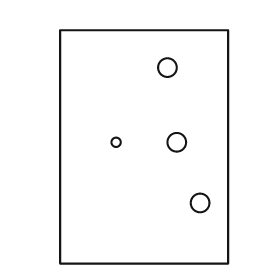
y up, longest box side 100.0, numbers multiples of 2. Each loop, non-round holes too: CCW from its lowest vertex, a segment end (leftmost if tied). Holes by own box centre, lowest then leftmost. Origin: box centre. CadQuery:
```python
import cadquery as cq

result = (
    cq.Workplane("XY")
    .moveTo(-36.0, -50.0)
    .lineTo(36.0, -50.0)
    .lineTo(36.0, 50.0)
    .lineTo(-36.0, 50.0)
    .close()
    .moveTo(24.0, -24.0)
    .circle(4.0)
    .moveTo(-12.0, 2.0)
    .circle(2.0)
    .moveTo(14.0, 2.0)
    .circle(4.0)
    .moveTo(10.0, 34.0)
    .circle(4.0)
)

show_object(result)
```